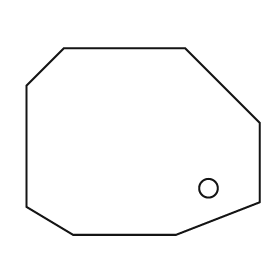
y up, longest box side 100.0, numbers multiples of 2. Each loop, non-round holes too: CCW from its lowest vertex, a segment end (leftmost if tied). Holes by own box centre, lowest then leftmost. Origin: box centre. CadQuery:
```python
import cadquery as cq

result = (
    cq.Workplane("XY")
    .moveTo(-30.0, -40.0)
    .lineTo(14.0, -40.0)
    .lineTo(50.0, -26.0)
    .lineTo(50.0, 8.0)
    .lineTo(18.0, 40.0)
    .lineTo(-34.0, 40.0)
    .lineTo(-50.0, 24.0)
    .lineTo(-50.0, -28.0)
    .close()
    .moveTo(28.0, -20.0)
    .circle(4.0)
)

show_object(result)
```